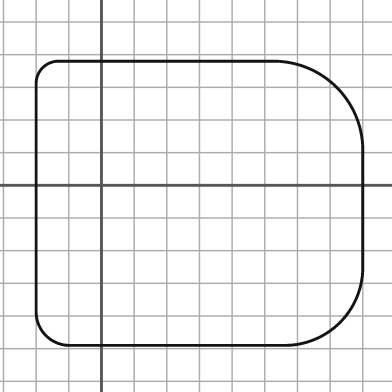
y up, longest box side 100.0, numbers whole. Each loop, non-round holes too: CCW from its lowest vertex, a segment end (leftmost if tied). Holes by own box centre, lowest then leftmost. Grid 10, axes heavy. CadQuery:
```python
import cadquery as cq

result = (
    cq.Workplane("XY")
    .moveTo(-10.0, -49.0)
    .lineTo(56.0, -49.0)
    .threePointArc((73.0, -42.0), (80.0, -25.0))
    .lineTo(80.0, 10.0)
    .threePointArc((72.0, 30.0), (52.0, 38.0))
    .lineTo(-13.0, 38.0)
    .threePointArc((-18.0, 36.0), (-20.0, 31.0))
    .lineTo(-20.0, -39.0)
    .threePointArc((-17.0, -46.0), (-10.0, -49.0))
    .close()
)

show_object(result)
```